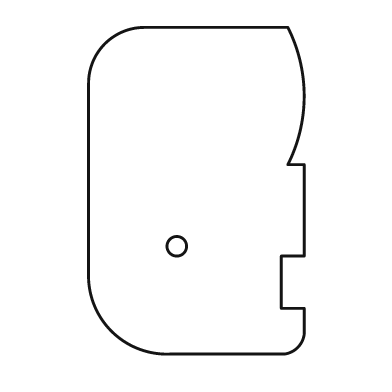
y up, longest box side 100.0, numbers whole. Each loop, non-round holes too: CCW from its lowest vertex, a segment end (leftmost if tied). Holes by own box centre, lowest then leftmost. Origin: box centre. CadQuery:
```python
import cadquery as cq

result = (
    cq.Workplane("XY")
    .moveTo(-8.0, -50.0)
    .lineTo(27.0, -50.0)
    .threePointArc((31.0, -48.0), (33.0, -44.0))
    .lineTo(33.0, -36.0)
    .lineTo(26.0, -36.0)
    .lineTo(26.0, -20.0)
    .lineTo(33.0, -20.0)
    .lineTo(33.0, 8.0)
    .lineTo(28.0, 8.0)
    .threePointArc((33.0, 29.0), (28.0, 50.0))
    .lineTo(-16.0, 50.0)
    .threePointArc((-28.0, 45.0), (-33.0, 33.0))
    .lineTo(-33.0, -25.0)
    .threePointArc((-26.0, -43.0), (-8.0, -50.0))
    .close()
    .moveTo(-6.0, -17.0)
    .circle(3.0)
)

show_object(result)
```